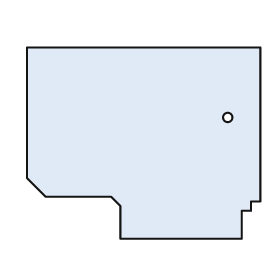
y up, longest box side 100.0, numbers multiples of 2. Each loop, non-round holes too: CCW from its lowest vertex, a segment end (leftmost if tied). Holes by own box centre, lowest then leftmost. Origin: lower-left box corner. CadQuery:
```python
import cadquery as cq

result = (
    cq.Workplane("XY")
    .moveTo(40.0, 0.0)
    .lineTo(92.0, 0.0)
    .lineTo(92.0, 12.0)
    .lineTo(96.0, 12.0)
    .lineTo(96.0, 16.0)
    .lineTo(100.0, 16.0)
    .lineTo(100.0, 82.0)
    .lineTo(0.0, 82.0)
    .lineTo(0.0, 26.0)
    .lineTo(8.0, 18.0)
    .lineTo(36.0, 18.0)
    .lineTo(40.0, 14.0)
    .close()
    .moveTo(86.0, 52.0)
    .circle(2.0)
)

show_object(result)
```